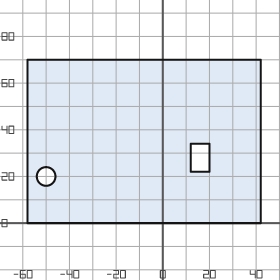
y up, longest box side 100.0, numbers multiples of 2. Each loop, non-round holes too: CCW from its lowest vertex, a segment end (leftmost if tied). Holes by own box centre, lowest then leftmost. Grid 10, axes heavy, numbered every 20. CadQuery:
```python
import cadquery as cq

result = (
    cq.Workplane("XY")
    .moveTo(-58.0, 0.0)
    .lineTo(42.0, 0.0)
    .lineTo(42.0, 70.0)
    .lineTo(-58.0, 70.0)
    .close()
    .moveTo(-50.0, 20.0)
    .circle(4.0)
    .moveTo(12.0, 22.0)
    .lineTo(20.0, 22.0)
    .lineTo(20.0, 34.0)
    .lineTo(12.0, 34.0)
    .close()
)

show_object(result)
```